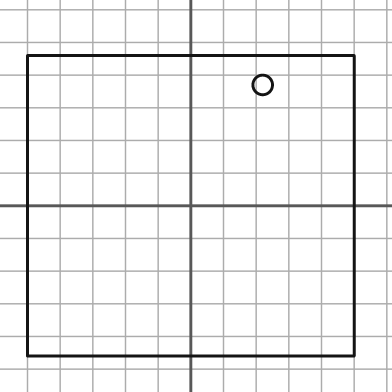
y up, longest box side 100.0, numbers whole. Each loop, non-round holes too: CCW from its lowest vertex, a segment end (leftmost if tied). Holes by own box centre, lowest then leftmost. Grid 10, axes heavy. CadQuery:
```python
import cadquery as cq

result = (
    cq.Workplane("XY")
    .moveTo(-50.0, -46.0)
    .lineTo(50.0, -46.0)
    .lineTo(50.0, 46.0)
    .lineTo(-50.0, 46.0)
    .close()
    .moveTo(22.0, 37.0)
    .circle(3.0)
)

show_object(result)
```